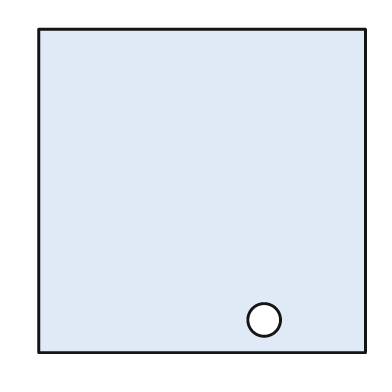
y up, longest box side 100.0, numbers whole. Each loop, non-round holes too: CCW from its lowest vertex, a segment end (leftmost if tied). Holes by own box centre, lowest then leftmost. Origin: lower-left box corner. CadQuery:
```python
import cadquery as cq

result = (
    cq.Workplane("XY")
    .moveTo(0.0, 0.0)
    .lineTo(100.0, 0.0)
    .lineTo(100.0, 99.0)
    .lineTo(0.0, 99.0)
    .close()
    .moveTo(69.0, 10.0)
    .circle(5.0)
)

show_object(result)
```